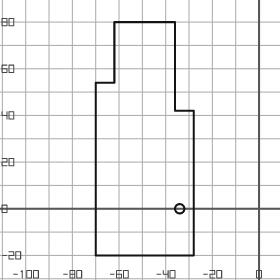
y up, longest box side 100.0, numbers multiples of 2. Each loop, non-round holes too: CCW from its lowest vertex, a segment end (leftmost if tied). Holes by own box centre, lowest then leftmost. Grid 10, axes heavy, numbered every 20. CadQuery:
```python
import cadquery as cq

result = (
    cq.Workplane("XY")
    .moveTo(-70.0, -20.0)
    .lineTo(-28.0, -20.0)
    .lineTo(-28.0, 42.0)
    .lineTo(-36.0, 42.0)
    .lineTo(-36.0, 80.0)
    .lineTo(-62.0, 80.0)
    .lineTo(-62.0, 54.0)
    .lineTo(-70.0, 54.0)
    .close()
    .moveTo(-34.0, 0.0)
    .circle(2.0)
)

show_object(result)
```